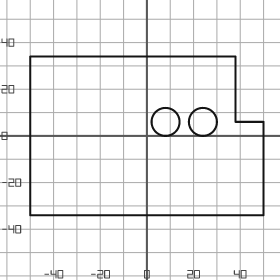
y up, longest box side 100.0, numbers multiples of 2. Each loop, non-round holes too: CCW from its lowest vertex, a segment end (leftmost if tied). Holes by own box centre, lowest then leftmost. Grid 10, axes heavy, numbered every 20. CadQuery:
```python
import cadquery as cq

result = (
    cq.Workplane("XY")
    .moveTo(-50.0, -34.0)
    .lineTo(50.0, -34.0)
    .lineTo(50.0, 6.0)
    .lineTo(38.0, 6.0)
    .lineTo(38.0, 34.0)
    .lineTo(-50.0, 34.0)
    .close()
    .moveTo(8.0, 6.0)
    .circle(6.0)
    .moveTo(24.0, 6.0)
    .circle(6.0)
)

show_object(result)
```